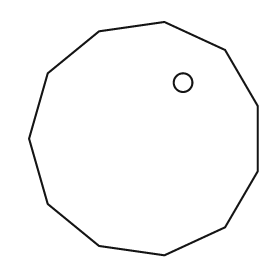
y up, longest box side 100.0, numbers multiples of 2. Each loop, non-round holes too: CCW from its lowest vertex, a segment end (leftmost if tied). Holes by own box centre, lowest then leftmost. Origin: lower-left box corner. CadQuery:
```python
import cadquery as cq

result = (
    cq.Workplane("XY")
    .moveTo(58.0, 0.0)
    .lineTo(84.0, 12.0)
    .lineTo(98.0, 36.0)
    .lineTo(98.0, 64.0)
    .lineTo(84.0, 88.0)
    .lineTo(58.0, 100.0)
    .lineTo(30.0, 96.0)
    .lineTo(8.0, 78.0)
    .lineTo(0.0, 50.0)
    .lineTo(8.0, 22.0)
    .lineTo(30.0, 4.0)
    .close()
    .moveTo(66.0, 74.0)
    .circle(4.0)
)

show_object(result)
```